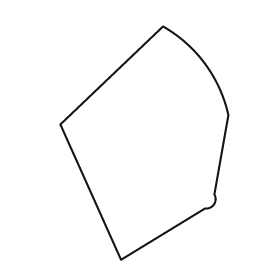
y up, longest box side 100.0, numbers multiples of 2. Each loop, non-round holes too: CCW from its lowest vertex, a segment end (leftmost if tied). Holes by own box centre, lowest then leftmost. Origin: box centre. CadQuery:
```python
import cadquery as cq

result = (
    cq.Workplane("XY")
    .moveTo(-10.0, -50.0)
    .lineTo(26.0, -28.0)
    .threePointArc((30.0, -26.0), (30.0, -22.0))
    .lineTo(36.0, 12.0)
    .threePointArc((26.0, 34.0), (8.0, 50.0))
    .lineTo(-36.0, 8.0)
    .close()
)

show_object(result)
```